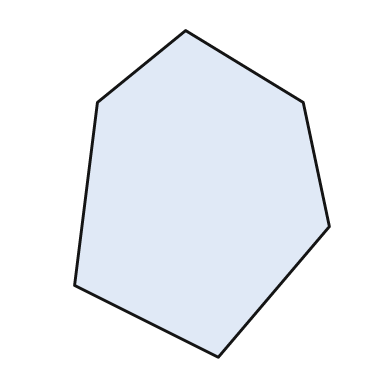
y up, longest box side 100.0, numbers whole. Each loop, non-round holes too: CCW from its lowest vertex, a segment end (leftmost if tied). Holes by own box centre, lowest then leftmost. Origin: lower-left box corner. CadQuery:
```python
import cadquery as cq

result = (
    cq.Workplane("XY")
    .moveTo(44.0, 0.0)
    .lineTo(78.0, 40.0)
    .lineTo(70.0, 78.0)
    .lineTo(34.0, 100.0)
    .lineTo(7.0, 78.0)
    .lineTo(0.0, 22.0)
    .close()
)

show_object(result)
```